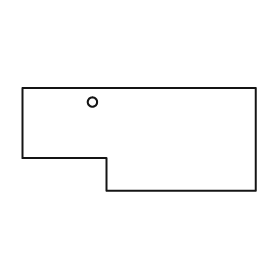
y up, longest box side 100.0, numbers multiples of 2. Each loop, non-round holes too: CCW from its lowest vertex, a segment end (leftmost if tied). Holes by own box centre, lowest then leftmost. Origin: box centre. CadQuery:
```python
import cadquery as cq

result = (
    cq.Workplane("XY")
    .moveTo(-14.0, -22.0)
    .lineTo(50.0, -22.0)
    .lineTo(50.0, 22.0)
    .lineTo(-50.0, 22.0)
    .lineTo(-50.0, -8.0)
    .lineTo(-14.0, -8.0)
    .close()
    .moveTo(-20.0, 16.0)
    .circle(2.0)
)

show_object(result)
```